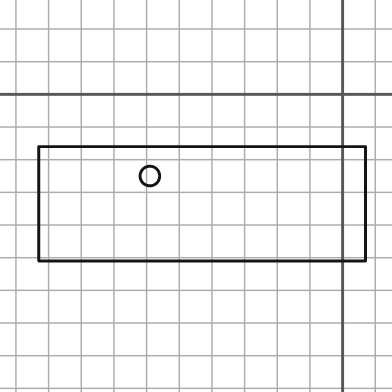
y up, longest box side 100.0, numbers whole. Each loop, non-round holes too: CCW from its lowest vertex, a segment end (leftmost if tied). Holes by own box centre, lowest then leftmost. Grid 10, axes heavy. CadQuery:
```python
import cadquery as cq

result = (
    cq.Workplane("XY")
    .moveTo(-93.0, -51.0)
    .lineTo(7.0, -51.0)
    .lineTo(7.0, -16.0)
    .lineTo(-93.0, -16.0)
    .close()
    .moveTo(-59.0, -25.0)
    .circle(3.0)
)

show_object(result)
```